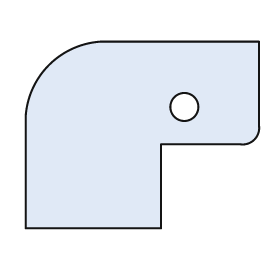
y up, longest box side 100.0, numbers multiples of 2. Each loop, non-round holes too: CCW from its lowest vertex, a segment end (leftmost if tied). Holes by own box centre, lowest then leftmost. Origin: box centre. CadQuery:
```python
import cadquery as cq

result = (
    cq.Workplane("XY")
    .moveTo(-50.0, -40.0)
    .lineTo(8.0, -40.0)
    .lineTo(8.0, -4.0)
    .lineTo(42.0, -4.0)
    .threePointArc((48.0, -2.0), (50.0, 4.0))
    .lineTo(50.0, 40.0)
    .lineTo(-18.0, 40.0)
    .threePointArc((-40.0, 30.0), (-50.0, 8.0))
    .close()
    .moveTo(18.0, 12.0)
    .circle(6.0)
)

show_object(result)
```